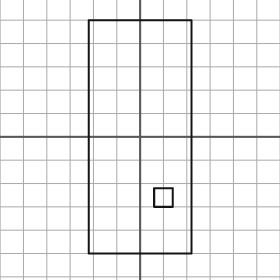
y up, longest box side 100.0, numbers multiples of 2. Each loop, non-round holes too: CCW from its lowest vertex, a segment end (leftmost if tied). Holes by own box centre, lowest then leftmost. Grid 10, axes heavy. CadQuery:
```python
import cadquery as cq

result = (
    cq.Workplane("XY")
    .moveTo(-22.0, -50.0)
    .lineTo(22.0, -50.0)
    .lineTo(22.0, 50.0)
    .lineTo(-22.0, 50.0)
    .close()
    .moveTo(6.0, -30.0)
    .lineTo(14.0, -30.0)
    .lineTo(14.0, -22.0)
    .lineTo(6.0, -22.0)
    .close()
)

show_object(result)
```